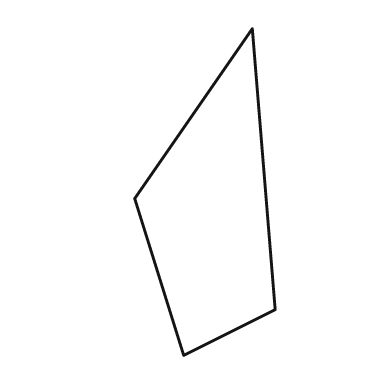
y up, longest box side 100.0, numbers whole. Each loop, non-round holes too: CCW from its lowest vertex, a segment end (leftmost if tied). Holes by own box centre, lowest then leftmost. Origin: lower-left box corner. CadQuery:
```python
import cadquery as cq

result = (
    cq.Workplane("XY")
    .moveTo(15.0, 0.0)
    .lineTo(43.0, 14.0)
    .lineTo(36.0, 100.0)
    .lineTo(0.0, 48.0)
    .close()
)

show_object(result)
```